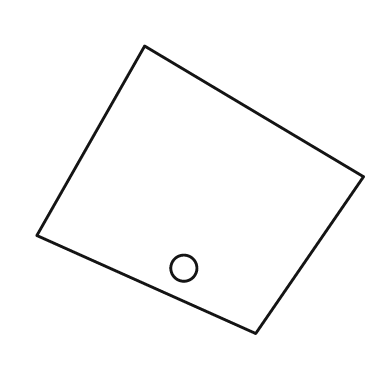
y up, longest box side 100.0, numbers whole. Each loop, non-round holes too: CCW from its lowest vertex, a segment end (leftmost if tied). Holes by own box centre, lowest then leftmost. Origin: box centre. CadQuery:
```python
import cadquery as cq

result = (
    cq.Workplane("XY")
    .moveTo(17.0, -44.0)
    .lineTo(50.0, 4.0)
    .lineTo(-17.0, 44.0)
    .lineTo(-50.0, -14.0)
    .close()
    .moveTo(-5.0, -24.0)
    .circle(4.0)
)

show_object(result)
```